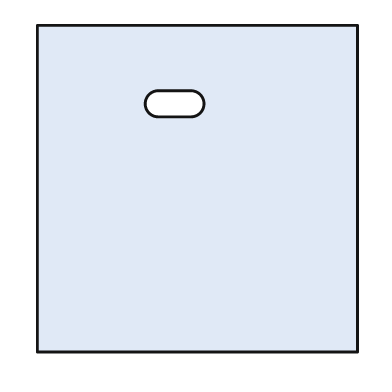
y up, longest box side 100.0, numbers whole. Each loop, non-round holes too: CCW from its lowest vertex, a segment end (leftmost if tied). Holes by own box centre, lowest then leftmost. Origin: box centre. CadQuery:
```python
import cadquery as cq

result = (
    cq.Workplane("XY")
    .moveTo(-49.0, -50.0)
    .lineTo(49.0, -50.0)
    .lineTo(49.0, 50.0)
    .lineTo(-49.0, 50.0)
    .close()
    .moveTo(-12.0, 22.0)
    .lineTo(-2.0, 22.0)
    .threePointArc((2.0, 26.0), (-2.0, 30.0))
    .lineTo(-12.0, 30.0)
    .threePointArc((-16.0, 26.0), (-12.0, 22.0))
    .close()
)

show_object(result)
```